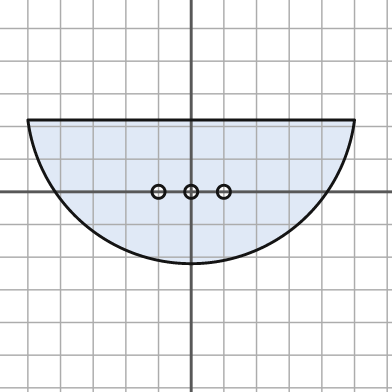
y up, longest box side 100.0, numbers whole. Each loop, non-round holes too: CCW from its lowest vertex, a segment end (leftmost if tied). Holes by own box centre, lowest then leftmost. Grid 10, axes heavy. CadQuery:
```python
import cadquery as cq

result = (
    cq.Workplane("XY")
    .moveTo(-50.0, 22.0)
    .threePointArc((0.0, -22.0), (50.0, 22.0))
    .close()
    .moveTo(-10.0, 0.0)
    .circle(2.0)
    .moveTo(0.0, 0.0)
    .circle(2.0)
    .moveTo(10.0, 0.0)
    .circle(2.0)
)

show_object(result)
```